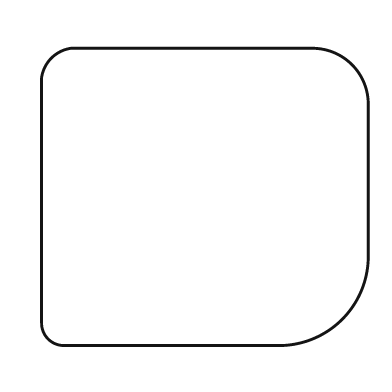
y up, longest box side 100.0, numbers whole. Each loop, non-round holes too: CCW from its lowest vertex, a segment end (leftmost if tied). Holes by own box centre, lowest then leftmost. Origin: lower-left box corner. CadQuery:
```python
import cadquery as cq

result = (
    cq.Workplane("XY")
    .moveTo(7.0, 0.0)
    .lineTo(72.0, 0.0)
    .threePointArc((92.0, 8.0), (100.0, 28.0))
    .lineTo(100.0, 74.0)
    .threePointArc((95.0, 86.0), (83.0, 91.0))
    .lineTo(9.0, 91.0)
    .threePointArc((3.0, 88.0), (0.0, 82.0))
    .lineTo(0.0, 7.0)
    .threePointArc((2.0, 2.0), (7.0, 0.0))
    .close()
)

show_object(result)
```